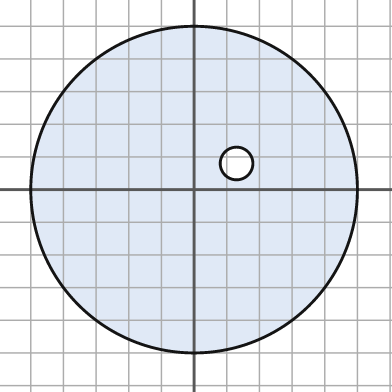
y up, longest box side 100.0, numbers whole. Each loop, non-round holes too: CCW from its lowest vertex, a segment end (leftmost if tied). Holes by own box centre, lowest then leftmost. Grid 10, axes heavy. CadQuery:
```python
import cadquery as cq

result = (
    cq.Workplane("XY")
    .moveTo(0.0, 0.0)
    .circle(50.0)
    .moveTo(13.0, 8.0)
    .circle(5.0)
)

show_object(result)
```